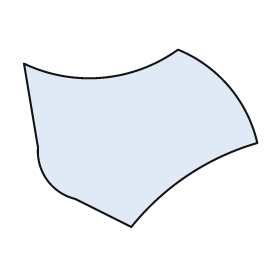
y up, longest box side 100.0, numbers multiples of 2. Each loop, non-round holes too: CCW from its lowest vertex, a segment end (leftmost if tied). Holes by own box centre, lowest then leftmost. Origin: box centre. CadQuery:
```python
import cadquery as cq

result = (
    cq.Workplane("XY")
    .moveTo(-4.0, -38.0)
    .threePointArc((20.0, -16.0), (50.0, -2.0))
    .threePointArc((38.0, 22.0), (16.0, 38.0))
    .threePointArc((-16.0, 26.0), (-50.0, 32.0))
    .lineTo(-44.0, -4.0)
    .threePointArc((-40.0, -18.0), (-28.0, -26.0))
    .close()
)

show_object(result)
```